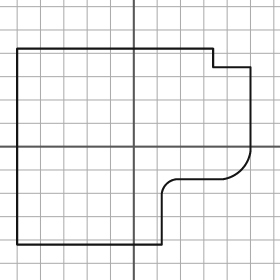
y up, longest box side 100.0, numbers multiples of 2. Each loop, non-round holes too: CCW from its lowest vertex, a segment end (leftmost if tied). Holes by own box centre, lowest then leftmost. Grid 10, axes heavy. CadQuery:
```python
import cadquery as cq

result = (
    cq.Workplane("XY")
    .moveTo(-50.0, -42.0)
    .lineTo(12.0, -42.0)
    .lineTo(12.0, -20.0)
    .threePointArc((14.0, -16.0), (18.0, -14.0))
    .lineTo(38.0, -14.0)
    .threePointArc((46.0, -10.0), (50.0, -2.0))
    .lineTo(50.0, 34.0)
    .lineTo(34.0, 34.0)
    .lineTo(34.0, 42.0)
    .lineTo(-50.0, 42.0)
    .close()
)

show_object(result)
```